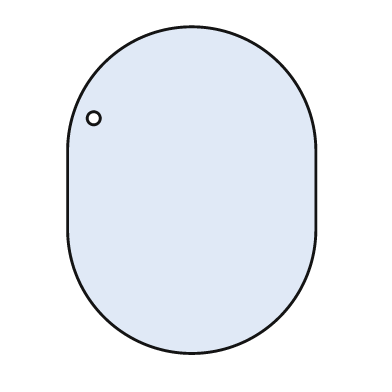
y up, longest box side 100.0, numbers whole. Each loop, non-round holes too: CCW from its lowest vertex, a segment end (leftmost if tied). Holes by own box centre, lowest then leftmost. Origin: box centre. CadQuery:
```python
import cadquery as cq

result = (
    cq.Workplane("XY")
    .moveTo(-38.0, -12.0)
    .threePointArc((0.0, -50.0), (38.0, -12.0))
    .lineTo(38.0, 12.0)
    .threePointArc((0.0, 50.0), (-38.0, 12.0))
    .close()
    .moveTo(-30.0, 22.0)
    .circle(2.0)
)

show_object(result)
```